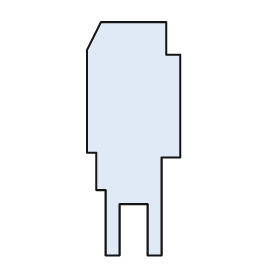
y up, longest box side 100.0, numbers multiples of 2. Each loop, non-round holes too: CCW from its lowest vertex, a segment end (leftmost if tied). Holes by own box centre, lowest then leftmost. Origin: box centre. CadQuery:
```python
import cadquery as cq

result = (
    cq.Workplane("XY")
    .moveTo(-12.0, -50.0)
    .lineTo(-6.0, -50.0)
    .lineTo(-6.0, -28.0)
    .lineTo(6.0, -28.0)
    .lineTo(6.0, -50.0)
    .lineTo(12.0, -50.0)
    .lineTo(12.0, -8.0)
    .lineTo(20.0, -8.0)
    .lineTo(20.0, 36.0)
    .lineTo(14.0, 36.0)
    .lineTo(14.0, 50.0)
    .lineTo(-14.0, 50.0)
    .lineTo(-20.0, 38.0)
    .lineTo(-20.0, -6.0)
    .lineTo(-16.0, -6.0)
    .lineTo(-16.0, -22.0)
    .lineTo(-12.0, -22.0)
    .close()
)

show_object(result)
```